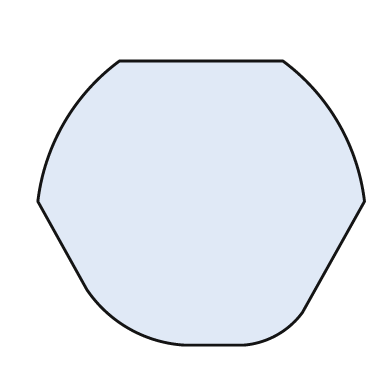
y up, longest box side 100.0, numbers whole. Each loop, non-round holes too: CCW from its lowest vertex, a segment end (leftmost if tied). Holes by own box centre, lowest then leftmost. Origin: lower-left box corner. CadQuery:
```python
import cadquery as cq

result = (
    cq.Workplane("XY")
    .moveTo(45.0, 0.0)
    .lineTo(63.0, 0.0)
    .threePointArc((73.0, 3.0), (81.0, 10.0))
    .lineTo(100.0, 44.0)
    .threePointArc((92.0, 68.0), (75.0, 87.0))
    .lineTo(25.0, 87.0)
    .threePointArc((8.0, 68.0), (0.0, 44.0))
    .lineTo(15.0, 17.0)
    .threePointArc((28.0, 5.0), (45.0, 0.0))
    .close()
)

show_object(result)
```